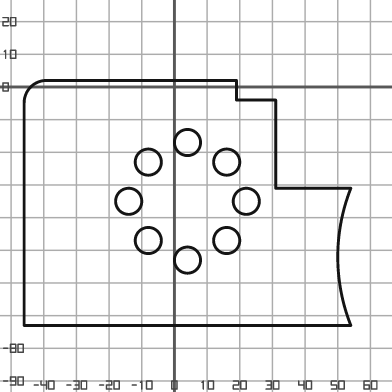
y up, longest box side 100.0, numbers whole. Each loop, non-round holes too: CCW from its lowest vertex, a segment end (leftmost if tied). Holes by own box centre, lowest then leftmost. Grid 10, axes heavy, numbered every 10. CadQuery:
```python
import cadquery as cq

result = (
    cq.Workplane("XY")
    .moveTo(-46.0, -73.0)
    .lineTo(54.0, -73.0)
    .threePointArc((50.0, -52.0), (54.0, -31.0))
    .lineTo(31.0, -31.0)
    .lineTo(31.0, -4.0)
    .lineTo(19.0, -4.0)
    .lineTo(19.0, 2.0)
    .lineTo(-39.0, 2.0)
    .threePointArc((-44.0, 0.0), (-46.0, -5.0))
    .close()
    .moveTo(4.0, -53.0)
    .circle(4.0)
    .moveTo(-8.0, -47.0)
    .circle(4.0)
    .moveTo(16.0, -47.0)
    .circle(4.0)
    .moveTo(-14.0, -35.0)
    .circle(4.0)
    .moveTo(22.0, -35.0)
    .circle(4.0)
    .moveTo(-8.0, -23.0)
    .circle(4.0)
    .moveTo(16.0, -23.0)
    .circle(4.0)
    .moveTo(4.0, -17.0)
    .circle(4.0)
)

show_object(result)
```